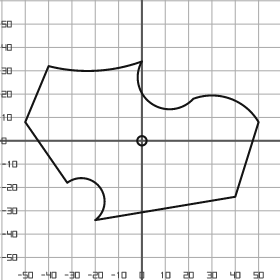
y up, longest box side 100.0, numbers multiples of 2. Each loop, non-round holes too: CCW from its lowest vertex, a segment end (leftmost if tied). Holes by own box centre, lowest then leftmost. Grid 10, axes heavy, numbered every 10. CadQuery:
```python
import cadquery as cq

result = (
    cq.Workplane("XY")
    .moveTo(-20.0, -34.0)
    .lineTo(40.0, -24.0)
    .lineTo(50.0, 8.0)
    .threePointArc((38.0, 18.0), (22.0, 18.0))
    .threePointArc((4.0, 16.0), (0.0, 34.0))
    .threePointArc((-20.0, 30.0), (-40.0, 32.0))
    .lineTo(-50.0, 8.0)
    .lineTo(-32.0, -18.0)
    .threePointArc((-18.0, -20.0), (-20.0, -34.0))
    .close()
    .moveTo(0.0, 0.0)
    .circle(2.0)
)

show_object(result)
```